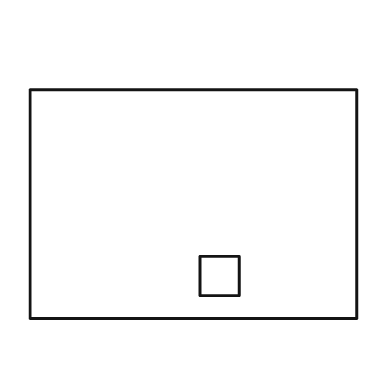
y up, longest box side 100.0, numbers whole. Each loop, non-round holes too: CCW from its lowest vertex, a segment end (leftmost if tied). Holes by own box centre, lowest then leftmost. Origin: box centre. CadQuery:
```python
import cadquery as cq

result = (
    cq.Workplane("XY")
    .moveTo(-50.0, -35.0)
    .lineTo(50.0, -35.0)
    .lineTo(50.0, 35.0)
    .lineTo(-50.0, 35.0)
    .close()
    .moveTo(2.0, -28.0)
    .lineTo(14.0, -28.0)
    .lineTo(14.0, -16.0)
    .lineTo(2.0, -16.0)
    .close()
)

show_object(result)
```